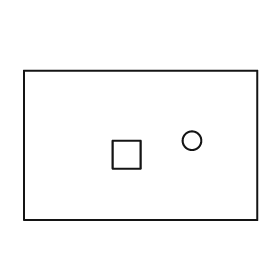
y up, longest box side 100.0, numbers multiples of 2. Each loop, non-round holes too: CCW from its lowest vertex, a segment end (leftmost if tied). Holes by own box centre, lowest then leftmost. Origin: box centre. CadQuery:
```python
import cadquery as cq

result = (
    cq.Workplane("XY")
    .moveTo(-50.0, -32.0)
    .lineTo(50.0, -32.0)
    .lineTo(50.0, 32.0)
    .lineTo(-50.0, 32.0)
    .close()
    .moveTo(-12.0, -10.0)
    .lineTo(0.0, -10.0)
    .lineTo(0.0, 2.0)
    .lineTo(-12.0, 2.0)
    .close()
    .moveTo(22.0, 2.0)
    .circle(4.0)
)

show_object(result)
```